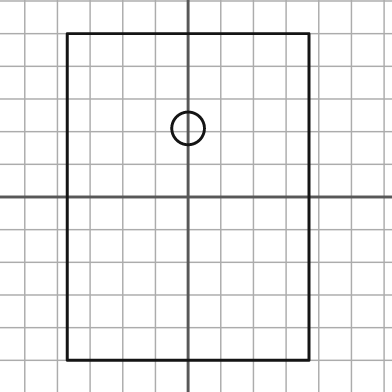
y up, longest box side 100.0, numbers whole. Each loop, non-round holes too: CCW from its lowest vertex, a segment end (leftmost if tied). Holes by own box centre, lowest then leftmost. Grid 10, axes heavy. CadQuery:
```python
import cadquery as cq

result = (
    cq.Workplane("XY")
    .moveTo(-37.0, -50.0)
    .lineTo(37.0, -50.0)
    .lineTo(37.0, 50.0)
    .lineTo(-37.0, 50.0)
    .close()
    .moveTo(0.0, 21.0)
    .circle(5.0)
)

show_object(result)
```